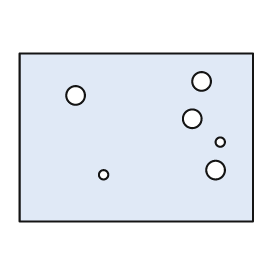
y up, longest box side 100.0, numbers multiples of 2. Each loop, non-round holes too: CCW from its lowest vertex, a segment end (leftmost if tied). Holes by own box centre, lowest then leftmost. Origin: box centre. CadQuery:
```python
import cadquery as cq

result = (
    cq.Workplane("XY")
    .moveTo(-50.0, -36.0)
    .lineTo(50.0, -36.0)
    .lineTo(50.0, 36.0)
    .lineTo(-50.0, 36.0)
    .close()
    .moveTo(-14.0, -16.0)
    .circle(2.0)
    .moveTo(34.0, -14.0)
    .circle(4.0)
    .moveTo(36.0, -2.0)
    .circle(2.0)
    .moveTo(24.0, 8.0)
    .circle(4.0)
    .moveTo(-26.0, 18.0)
    .circle(4.0)
    .moveTo(28.0, 24.0)
    .circle(4.0)
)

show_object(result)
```